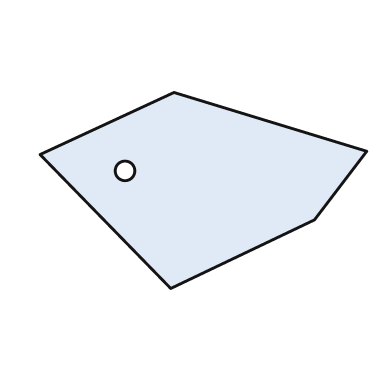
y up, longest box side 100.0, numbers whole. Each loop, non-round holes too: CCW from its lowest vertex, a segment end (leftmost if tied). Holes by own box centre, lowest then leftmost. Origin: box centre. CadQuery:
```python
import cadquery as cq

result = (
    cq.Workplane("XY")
    .moveTo(-10.0, -30.0)
    .lineTo(34.0, -9.0)
    .lineTo(50.0, 12.0)
    .lineTo(-9.0, 30.0)
    .lineTo(-50.0, 11.0)
    .close()
    .moveTo(-24.0, 6.0)
    .circle(3.0)
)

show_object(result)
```